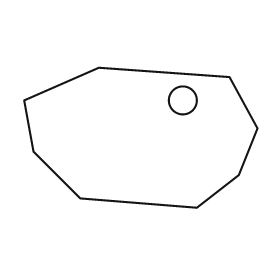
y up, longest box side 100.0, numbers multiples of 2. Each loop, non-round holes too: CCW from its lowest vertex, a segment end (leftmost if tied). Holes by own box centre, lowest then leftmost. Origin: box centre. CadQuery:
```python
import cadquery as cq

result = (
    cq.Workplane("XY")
    .moveTo(24.0, -30.0)
    .lineTo(42.0, -16.0)
    .lineTo(50.0, 4.0)
    .lineTo(38.0, 26.0)
    .lineTo(-18.0, 30.0)
    .lineTo(-50.0, 16.0)
    .lineTo(-46.0, -6.0)
    .lineTo(-26.0, -26.0)
    .close()
    .moveTo(18.0, 16.0)
    .circle(6.0)
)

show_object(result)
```